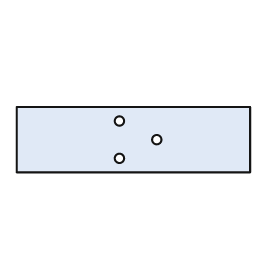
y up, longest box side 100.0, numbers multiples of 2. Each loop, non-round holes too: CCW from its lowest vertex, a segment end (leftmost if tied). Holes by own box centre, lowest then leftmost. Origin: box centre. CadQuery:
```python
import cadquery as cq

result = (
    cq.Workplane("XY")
    .moveTo(-50.0, -14.0)
    .lineTo(50.0, -14.0)
    .lineTo(50.0, 14.0)
    .lineTo(-50.0, 14.0)
    .close()
    .moveTo(-6.0, -8.0)
    .circle(2.0)
    .moveTo(10.0, 0.0)
    .circle(2.0)
    .moveTo(-6.0, 8.0)
    .circle(2.0)
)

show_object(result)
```